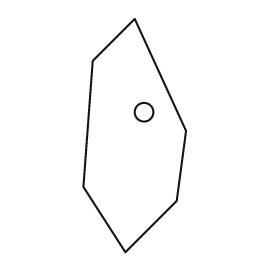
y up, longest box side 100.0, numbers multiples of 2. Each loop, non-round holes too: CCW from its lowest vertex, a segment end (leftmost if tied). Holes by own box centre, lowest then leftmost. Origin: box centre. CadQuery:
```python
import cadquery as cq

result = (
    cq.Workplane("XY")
    .moveTo(-4.0, -50.0)
    .lineTo(18.0, -28.0)
    .lineTo(22.0, 2.0)
    .lineTo(0.0, 50.0)
    .lineTo(-18.0, 32.0)
    .lineTo(-22.0, -22.0)
    .close()
    .moveTo(4.0, 10.0)
    .circle(4.0)
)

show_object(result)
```